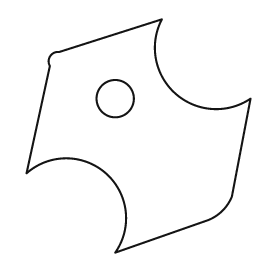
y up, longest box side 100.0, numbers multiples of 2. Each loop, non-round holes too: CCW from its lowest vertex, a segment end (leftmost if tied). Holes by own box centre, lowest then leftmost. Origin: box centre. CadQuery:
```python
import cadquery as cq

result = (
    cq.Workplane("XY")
    .moveTo(-10.0, -50.0)
    .lineTo(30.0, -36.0)
    .threePointArc((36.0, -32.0), (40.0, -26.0))
    .lineTo(48.0, 16.0)
    .threePointArc((16.0, 18.0), (10.0, 50.0))
    .lineTo(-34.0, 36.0)
    .threePointArc((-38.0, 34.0), (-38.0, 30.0))
    .lineTo(-48.0, -16.0)
    .threePointArc((-14.0, -16.0), (-10.0, -50.0))
    .close()
    .moveTo(-10.0, 16.0)
    .circle(8.0)
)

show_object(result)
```